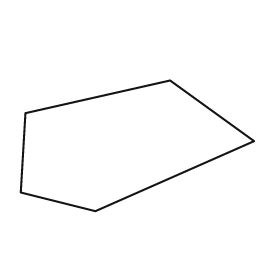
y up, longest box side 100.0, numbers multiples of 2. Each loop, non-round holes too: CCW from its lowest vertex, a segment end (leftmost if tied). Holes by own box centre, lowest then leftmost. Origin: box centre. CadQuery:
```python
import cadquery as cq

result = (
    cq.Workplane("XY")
    .moveTo(-18.0, -28.0)
    .lineTo(50.0, 2.0)
    .lineTo(14.0, 28.0)
    .lineTo(-48.0, 14.0)
    .lineTo(-50.0, -20.0)
    .close()
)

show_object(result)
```